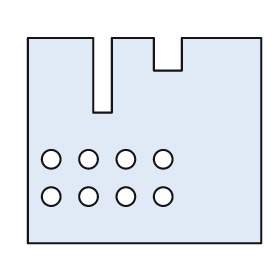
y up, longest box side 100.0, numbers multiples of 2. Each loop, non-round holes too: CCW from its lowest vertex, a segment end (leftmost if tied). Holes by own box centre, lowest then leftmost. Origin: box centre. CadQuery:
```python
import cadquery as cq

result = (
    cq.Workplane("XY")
    .moveTo(-50.0, -44.0)
    .lineTo(50.0, -44.0)
    .lineTo(50.0, 44.0)
    .lineTo(16.0, 44.0)
    .lineTo(16.0, 30.0)
    .lineTo(4.0, 30.0)
    .lineTo(4.0, 44.0)
    .lineTo(-14.0, 44.0)
    .lineTo(-14.0, 12.0)
    .lineTo(-22.0, 12.0)
    .lineTo(-22.0, 44.0)
    .lineTo(-50.0, 44.0)
    .close()
    .moveTo(-40.0, -24.0)
    .circle(4.0)
    .moveTo(-24.0, -24.0)
    .circle(4.0)
    .moveTo(-8.0, -24.0)
    .circle(4.0)
    .moveTo(8.0, -24.0)
    .circle(4.0)
    .moveTo(-40.0, -8.0)
    .circle(4.0)
    .moveTo(-24.0, -8.0)
    .circle(4.0)
    .moveTo(-8.0, -8.0)
    .circle(4.0)
    .moveTo(8.0, -8.0)
    .circle(4.0)
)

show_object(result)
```